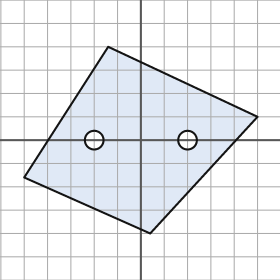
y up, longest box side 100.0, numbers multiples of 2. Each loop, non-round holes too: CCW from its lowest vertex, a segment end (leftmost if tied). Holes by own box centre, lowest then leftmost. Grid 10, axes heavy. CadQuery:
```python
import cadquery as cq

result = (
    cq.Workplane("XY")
    .moveTo(4.0, -40.0)
    .lineTo(50.0, 10.0)
    .lineTo(-14.0, 40.0)
    .lineTo(-50.0, -16.0)
    .close()
    .moveTo(-20.0, 0.0)
    .circle(4.0)
    .moveTo(20.0, 0.0)
    .circle(4.0)
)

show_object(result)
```